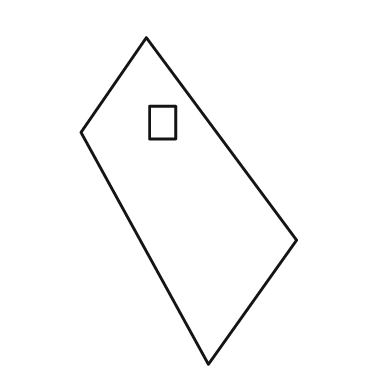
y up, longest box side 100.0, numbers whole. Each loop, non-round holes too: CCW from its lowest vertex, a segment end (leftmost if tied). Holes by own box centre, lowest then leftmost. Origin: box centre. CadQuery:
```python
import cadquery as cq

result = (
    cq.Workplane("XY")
    .moveTo(6.0, -50.0)
    .lineTo(33.0, -12.0)
    .lineTo(-13.0, 50.0)
    .lineTo(-33.0, 21.0)
    .close()
    .moveTo(-12.0, 19.0)
    .lineTo(-4.0, 19.0)
    .lineTo(-4.0, 29.0)
    .lineTo(-12.0, 29.0)
    .close()
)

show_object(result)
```